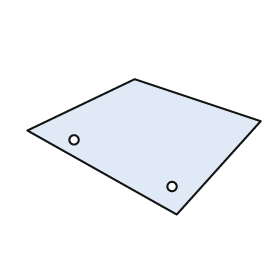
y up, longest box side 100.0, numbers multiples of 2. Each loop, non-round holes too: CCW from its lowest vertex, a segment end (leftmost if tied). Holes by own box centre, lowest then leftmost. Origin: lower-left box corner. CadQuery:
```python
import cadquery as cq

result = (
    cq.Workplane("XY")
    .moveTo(64.0, 0.0)
    .lineTo(100.0, 40.0)
    .lineTo(46.0, 58.0)
    .lineTo(0.0, 36.0)
    .close()
    .moveTo(62.0, 12.0)
    .circle(2.0)
    .moveTo(20.0, 32.0)
    .circle(2.0)
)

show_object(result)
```